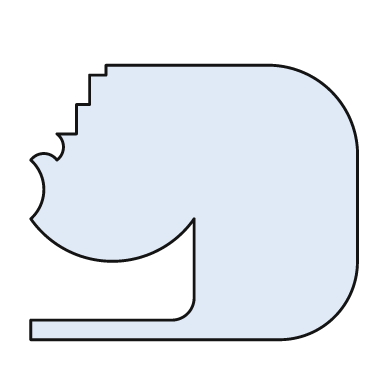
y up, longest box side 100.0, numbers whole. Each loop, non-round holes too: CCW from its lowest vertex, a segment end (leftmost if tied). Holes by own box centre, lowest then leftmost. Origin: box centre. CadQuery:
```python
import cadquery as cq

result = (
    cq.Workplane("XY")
    .moveTo(-50.0, -42.0)
    .lineTo(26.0, -42.0)
    .threePointArc((43.0, -35.0), (50.0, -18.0))
    .lineTo(50.0, 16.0)
    .threePointArc((42.0, 34.0), (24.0, 42.0))
    .lineTo(-27.0, 42.0)
    .lineTo(-27.0, 39.0)
    .lineTo(-32.0, 39.0)
    .lineTo(-32.0, 30.0)
    .lineTo(-36.0, 30.0)
    .lineTo(-36.0, 21.0)
    .lineTo(-42.0, 21.0)
    .threePointArc((-40.0, 17.0), (-42.0, 13.0))
    .threePointArc((-46.0, 15.0), (-50.0, 13.0))
    .threePointArc((-46.0, 4.0), (-50.0, -5.0))
    .threePointArc((-25.0, -18.0), (0.0, -5.0))
    .lineTo(0.0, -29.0)
    .threePointArc((-2.0, -34.0), (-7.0, -36.0))
    .lineTo(-50.0, -36.0)
    .close()
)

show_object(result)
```